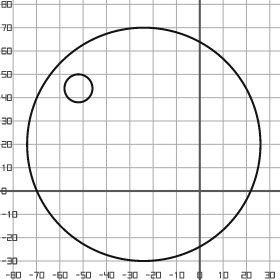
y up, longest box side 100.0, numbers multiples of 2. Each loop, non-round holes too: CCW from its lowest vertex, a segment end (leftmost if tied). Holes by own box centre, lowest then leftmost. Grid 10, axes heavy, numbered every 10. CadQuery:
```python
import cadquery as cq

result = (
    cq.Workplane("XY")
    .moveTo(-24.0, 20.0)
    .circle(50.0)
    .moveTo(-52.0, 44.0)
    .circle(6.0)
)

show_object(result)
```